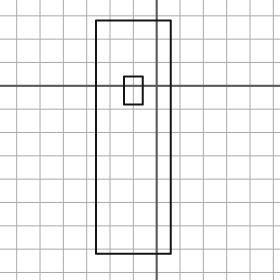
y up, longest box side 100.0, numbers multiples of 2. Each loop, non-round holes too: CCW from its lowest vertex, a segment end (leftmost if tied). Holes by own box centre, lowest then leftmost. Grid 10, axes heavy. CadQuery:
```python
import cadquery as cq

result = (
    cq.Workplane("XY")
    .moveTo(-26.0, -72.0)
    .lineTo(6.0, -72.0)
    .lineTo(6.0, 28.0)
    .lineTo(-26.0, 28.0)
    .close()
    .moveTo(-14.0, -8.0)
    .lineTo(-6.0, -8.0)
    .lineTo(-6.0, 4.0)
    .lineTo(-14.0, 4.0)
    .close()
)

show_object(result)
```